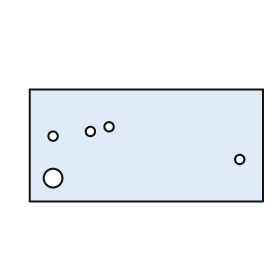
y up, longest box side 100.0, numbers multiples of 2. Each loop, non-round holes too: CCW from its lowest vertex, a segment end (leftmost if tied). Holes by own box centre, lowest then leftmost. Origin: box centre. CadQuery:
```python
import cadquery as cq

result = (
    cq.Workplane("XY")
    .moveTo(-50.0, -24.0)
    .lineTo(50.0, -24.0)
    .lineTo(50.0, 24.0)
    .lineTo(-50.0, 24.0)
    .close()
    .moveTo(-40.0, -14.0)
    .circle(4.0)
    .moveTo(40.0, -6.0)
    .circle(2.0)
    .moveTo(-40.0, 4.0)
    .circle(2.0)
    .moveTo(-24.0, 6.0)
    .circle(2.0)
    .moveTo(-16.0, 8.0)
    .circle(2.0)
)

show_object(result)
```